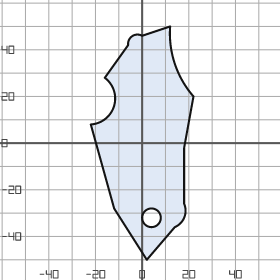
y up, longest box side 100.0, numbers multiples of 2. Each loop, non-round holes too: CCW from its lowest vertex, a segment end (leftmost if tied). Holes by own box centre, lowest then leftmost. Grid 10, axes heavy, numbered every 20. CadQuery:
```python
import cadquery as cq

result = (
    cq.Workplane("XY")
    .moveTo(2.0, -50.0)
    .lineTo(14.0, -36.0)
    .threePointArc((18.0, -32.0), (18.0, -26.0))
    .lineTo(18.0, -2.0)
    .lineTo(22.0, 20.0)
    .threePointArc((14.0, 34.0), (12.0, 50.0))
    .lineTo(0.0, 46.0)
    .threePointArc((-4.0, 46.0), (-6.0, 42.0))
    .lineTo(-16.0, 28.0)
    .threePointArc((-12.0, 16.0), (-22.0, 8.0))
    .lineTo(-12.0, -28.0)
    .close()
    .moveTo(4.0, -32.0)
    .circle(4.0)
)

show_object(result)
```